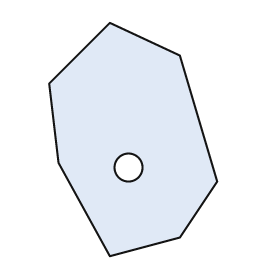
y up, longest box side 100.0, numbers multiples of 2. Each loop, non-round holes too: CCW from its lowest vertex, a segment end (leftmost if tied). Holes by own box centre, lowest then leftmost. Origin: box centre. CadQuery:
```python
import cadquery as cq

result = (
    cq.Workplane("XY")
    .moveTo(-10.0, -50.0)
    .lineTo(20.0, -42.0)
    .lineTo(36.0, -18.0)
    .lineTo(20.0, 36.0)
    .lineTo(-10.0, 50.0)
    .lineTo(-36.0, 24.0)
    .lineTo(-32.0, -10.0)
    .close()
    .moveTo(-2.0, -12.0)
    .circle(6.0)
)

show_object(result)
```